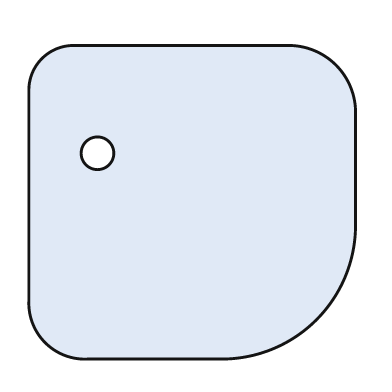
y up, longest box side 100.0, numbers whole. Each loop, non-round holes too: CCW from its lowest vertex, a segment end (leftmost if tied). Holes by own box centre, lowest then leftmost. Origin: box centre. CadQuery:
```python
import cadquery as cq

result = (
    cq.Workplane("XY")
    .moveTo(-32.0, -48.0)
    .lineTo(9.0, -48.0)
    .threePointArc((38.0, -36.0), (50.0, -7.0))
    .lineTo(50.0, 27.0)
    .threePointArc((44.0, 42.0), (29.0, 48.0))
    .lineTo(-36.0, 48.0)
    .threePointArc((-46.0, 44.0), (-50.0, 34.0))
    .lineTo(-50.0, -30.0)
    .threePointArc((-45.0, -43.0), (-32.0, -48.0))
    .close()
    .moveTo(-29.0, 15.0)
    .circle(5.0)
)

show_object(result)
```